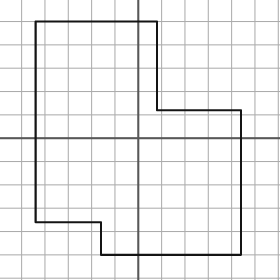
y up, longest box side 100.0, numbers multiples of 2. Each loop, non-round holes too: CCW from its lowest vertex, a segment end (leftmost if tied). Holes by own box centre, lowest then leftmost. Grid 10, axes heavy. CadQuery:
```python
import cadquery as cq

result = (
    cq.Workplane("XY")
    .moveTo(-16.0, -50.0)
    .lineTo(44.0, -50.0)
    .lineTo(44.0, 12.0)
    .lineTo(8.0, 12.0)
    .lineTo(8.0, 50.0)
    .lineTo(-44.0, 50.0)
    .lineTo(-44.0, -36.0)
    .lineTo(-16.0, -36.0)
    .close()
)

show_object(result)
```